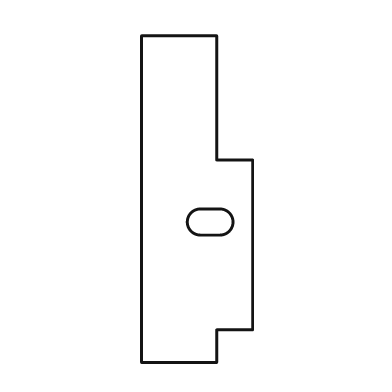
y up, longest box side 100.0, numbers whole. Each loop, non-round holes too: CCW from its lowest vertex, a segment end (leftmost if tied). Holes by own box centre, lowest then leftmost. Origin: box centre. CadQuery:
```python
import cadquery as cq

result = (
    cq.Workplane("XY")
    .moveTo(-17.0, -50.0)
    .lineTo(6.0, -50.0)
    .lineTo(6.0, -40.0)
    .lineTo(17.0, -40.0)
    .lineTo(17.0, 12.0)
    .lineTo(6.0, 12.0)
    .lineTo(6.0, 50.0)
    .lineTo(-17.0, 50.0)
    .close()
    .moveTo(1.0, -11.0)
    .lineTo(7.0, -11.0)
    .threePointArc((11.0, -7.0), (7.0, -3.0))
    .lineTo(1.0, -3.0)
    .threePointArc((-3.0, -7.0), (1.0, -11.0))
    .close()
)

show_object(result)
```